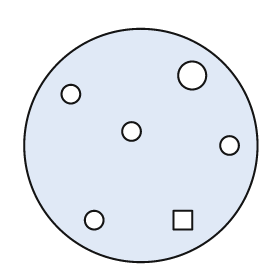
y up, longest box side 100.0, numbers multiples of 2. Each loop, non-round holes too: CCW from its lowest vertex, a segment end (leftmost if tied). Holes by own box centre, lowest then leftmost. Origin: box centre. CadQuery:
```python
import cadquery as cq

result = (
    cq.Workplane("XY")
    .moveTo(0.0, 0.0)
    .circle(50.0)
    .moveTo(-20.0, -32.0)
    .circle(4.0)
    .moveTo(14.0, -36.0)
    .lineTo(22.0, -36.0)
    .lineTo(22.0, -28.0)
    .lineTo(14.0, -28.0)
    .close()
    .moveTo(38.0, 0.0)
    .circle(4.0)
    .moveTo(-4.0, 6.0)
    .circle(4.0)
    .moveTo(-30.0, 22.0)
    .circle(4.0)
    .moveTo(22.0, 30.0)
    .circle(6.0)
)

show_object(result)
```